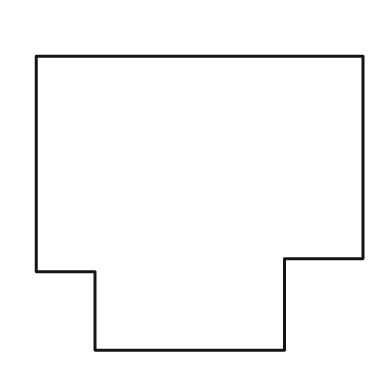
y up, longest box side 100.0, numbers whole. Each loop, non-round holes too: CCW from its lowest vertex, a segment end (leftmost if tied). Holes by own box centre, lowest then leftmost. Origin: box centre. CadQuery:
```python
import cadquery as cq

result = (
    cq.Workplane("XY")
    .moveTo(-32.0, -45.0)
    .lineTo(26.0, -45.0)
    .lineTo(26.0, -17.0)
    .lineTo(50.0, -17.0)
    .lineTo(50.0, 45.0)
    .lineTo(-50.0, 45.0)
    .lineTo(-50.0, -21.0)
    .lineTo(-32.0, -21.0)
    .close()
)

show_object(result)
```